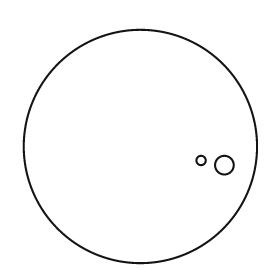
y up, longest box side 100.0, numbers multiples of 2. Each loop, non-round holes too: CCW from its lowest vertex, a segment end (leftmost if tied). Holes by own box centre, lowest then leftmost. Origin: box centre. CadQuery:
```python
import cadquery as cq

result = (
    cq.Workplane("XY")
    .moveTo(0.0, 0.0)
    .circle(50.0)
    .moveTo(36.0, -8.0)
    .circle(4.0)
    .moveTo(26.0, -6.0)
    .circle(2.0)
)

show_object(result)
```